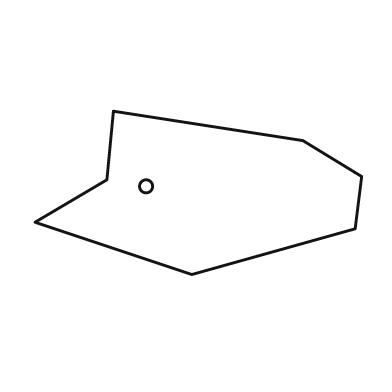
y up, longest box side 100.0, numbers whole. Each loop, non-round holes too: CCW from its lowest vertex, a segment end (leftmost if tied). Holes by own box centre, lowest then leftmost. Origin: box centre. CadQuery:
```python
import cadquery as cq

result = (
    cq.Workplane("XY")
    .moveTo(-2.0, -25.0)
    .lineTo(48.0, -11.0)
    .lineTo(50.0, 5.0)
    .lineTo(32.0, 16.0)
    .lineTo(-26.0, 25.0)
    .lineTo(-28.0, 4.0)
    .lineTo(-50.0, -9.0)
    .close()
    .moveTo(-16.0, 2.0)
    .circle(2.0)
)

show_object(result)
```